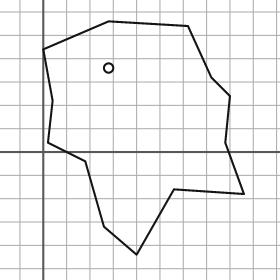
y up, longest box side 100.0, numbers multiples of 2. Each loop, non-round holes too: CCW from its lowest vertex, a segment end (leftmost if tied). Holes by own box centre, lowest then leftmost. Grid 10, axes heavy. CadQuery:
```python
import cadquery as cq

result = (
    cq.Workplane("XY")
    .moveTo(40.0, -44.0)
    .lineTo(56.0, -16.0)
    .lineTo(86.0, -18.0)
    .lineTo(78.0, 4.0)
    .lineTo(80.0, 24.0)
    .lineTo(72.0, 32.0)
    .lineTo(62.0, 54.0)
    .lineTo(28.0, 56.0)
    .lineTo(0.0, 44.0)
    .lineTo(4.0, 22.0)
    .lineTo(2.0, 4.0)
    .lineTo(18.0, -4.0)
    .lineTo(26.0, -32.0)
    .close()
    .moveTo(28.0, 36.0)
    .circle(2.0)
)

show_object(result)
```